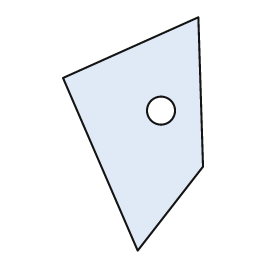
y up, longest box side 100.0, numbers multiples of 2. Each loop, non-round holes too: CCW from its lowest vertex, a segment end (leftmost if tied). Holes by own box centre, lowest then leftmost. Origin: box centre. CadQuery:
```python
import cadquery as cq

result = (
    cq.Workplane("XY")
    .moveTo(2.0, -50.0)
    .lineTo(30.0, -14.0)
    .lineTo(28.0, 50.0)
    .lineTo(-30.0, 24.0)
    .close()
    .moveTo(12.0, 10.0)
    .circle(6.0)
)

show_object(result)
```